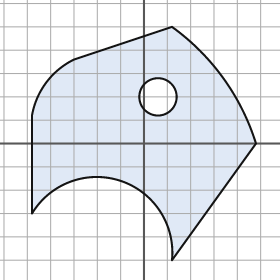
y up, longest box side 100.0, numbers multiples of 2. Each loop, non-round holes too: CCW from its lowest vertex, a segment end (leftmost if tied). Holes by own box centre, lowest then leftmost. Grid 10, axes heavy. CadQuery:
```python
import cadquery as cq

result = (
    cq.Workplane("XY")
    .moveTo(12.0, -50.0)
    .lineTo(48.0, 0.0)
    .threePointArc((34.0, 28.0), (12.0, 50.0))
    .lineTo(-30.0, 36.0)
    .threePointArc((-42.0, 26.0), (-48.0, 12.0))
    .lineTo(-48.0, -30.0)
    .threePointArc((-10.0, -16.0), (12.0, -50.0))
    .close()
    .moveTo(6.0, 20.0)
    .circle(8.0)
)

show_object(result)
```